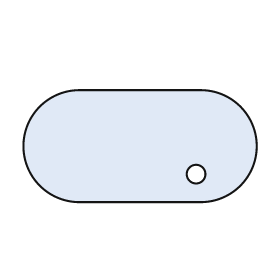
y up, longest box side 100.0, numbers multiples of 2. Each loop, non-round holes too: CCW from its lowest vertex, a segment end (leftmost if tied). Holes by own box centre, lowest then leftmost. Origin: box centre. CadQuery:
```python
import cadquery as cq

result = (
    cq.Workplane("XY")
    .moveTo(-26.0, -24.0)
    .lineTo(26.0, -24.0)
    .threePointArc((50.0, 0.0), (26.0, 24.0))
    .lineTo(-26.0, 24.0)
    .threePointArc((-50.0, 0.0), (-26.0, -24.0))
    .close()
    .moveTo(24.0, -12.0)
    .circle(4.0)
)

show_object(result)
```